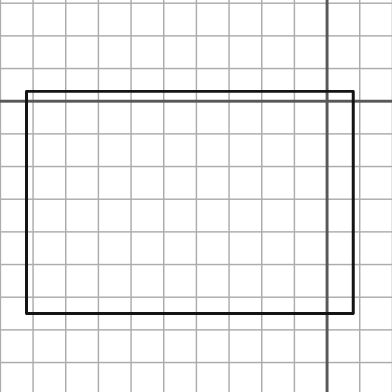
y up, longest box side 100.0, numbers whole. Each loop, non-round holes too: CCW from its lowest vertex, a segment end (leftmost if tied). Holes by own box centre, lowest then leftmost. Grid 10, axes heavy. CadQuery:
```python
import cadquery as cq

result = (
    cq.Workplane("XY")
    .moveTo(-92.0, -65.0)
    .lineTo(8.0, -65.0)
    .lineTo(8.0, 3.0)
    .lineTo(-92.0, 3.0)
    .close()
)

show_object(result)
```